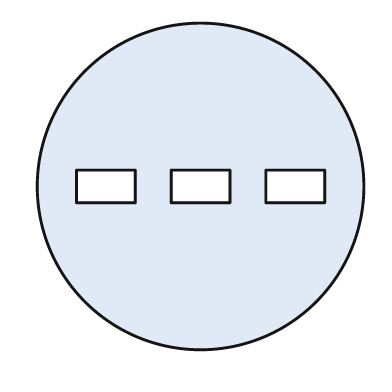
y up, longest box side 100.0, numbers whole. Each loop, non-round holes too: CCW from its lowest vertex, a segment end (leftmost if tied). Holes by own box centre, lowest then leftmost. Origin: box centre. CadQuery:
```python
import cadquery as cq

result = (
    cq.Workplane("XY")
    .moveTo(0.0, 0.0)
    .circle(50.0)
    .moveTo(-38.0, -5.0)
    .lineTo(-20.0, -5.0)
    .lineTo(-20.0, 5.0)
    .lineTo(-38.0, 5.0)
    .close()
    .moveTo(-9.0, -5.0)
    .lineTo(9.0, -5.0)
    .lineTo(9.0, 5.0)
    .lineTo(-9.0, 5.0)
    .close()
    .moveTo(20.0, -5.0)
    .lineTo(38.0, -5.0)
    .lineTo(38.0, 5.0)
    .lineTo(20.0, 5.0)
    .close()
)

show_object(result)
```